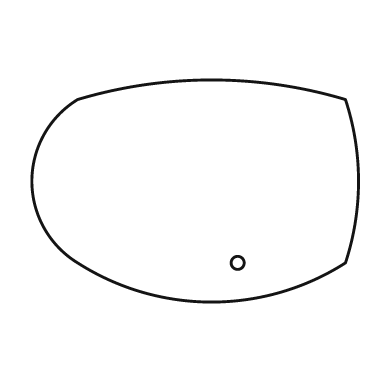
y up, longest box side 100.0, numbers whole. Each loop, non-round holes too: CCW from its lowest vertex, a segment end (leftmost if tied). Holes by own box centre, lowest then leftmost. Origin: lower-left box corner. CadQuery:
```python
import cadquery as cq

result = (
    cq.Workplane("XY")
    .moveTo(14.0, 12.0)
    .threePointArc((55.0, 0.0), (96.0, 12.0))
    .threePointArc((100.0, 37.0), (96.0, 62.0))
    .threePointArc((55.0, 68.0), (14.0, 62.0))
    .threePointArc((0.0, 37.0), (14.0, 12.0))
    .close()
    .moveTo(63.0, 12.0)
    .circle(2.0)
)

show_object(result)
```